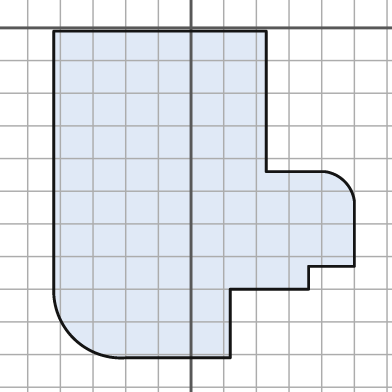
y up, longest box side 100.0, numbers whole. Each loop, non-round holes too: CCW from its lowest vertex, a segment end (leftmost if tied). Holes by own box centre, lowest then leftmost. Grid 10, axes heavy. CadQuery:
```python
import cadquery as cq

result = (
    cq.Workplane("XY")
    .moveTo(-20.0, -101.0)
    .lineTo(12.0, -101.0)
    .lineTo(12.0, -80.0)
    .lineTo(36.0, -80.0)
    .lineTo(36.0, -73.0)
    .lineTo(50.0, -73.0)
    .lineTo(50.0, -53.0)
    .threePointArc((47.0, -47.0), (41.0, -44.0))
    .lineTo(23.0, -44.0)
    .lineTo(23.0, -1.0)
    .lineTo(-42.0, -1.0)
    .lineTo(-42.0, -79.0)
    .threePointArc((-36.0, -95.0), (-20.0, -101.0))
    .close()
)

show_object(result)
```